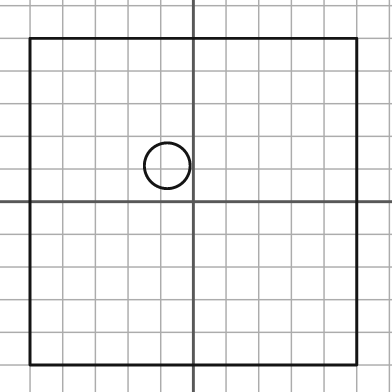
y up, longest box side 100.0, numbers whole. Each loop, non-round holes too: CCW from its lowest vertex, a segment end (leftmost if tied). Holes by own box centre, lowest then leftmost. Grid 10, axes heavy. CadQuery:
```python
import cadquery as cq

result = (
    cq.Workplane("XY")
    .moveTo(-50.0, -50.0)
    .lineTo(50.0, -50.0)
    .lineTo(50.0, 50.0)
    .lineTo(-50.0, 50.0)
    .close()
    .moveTo(-8.0, 11.0)
    .circle(7.0)
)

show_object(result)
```